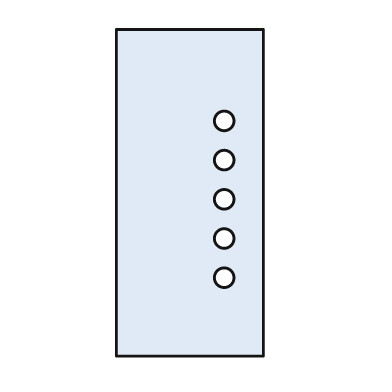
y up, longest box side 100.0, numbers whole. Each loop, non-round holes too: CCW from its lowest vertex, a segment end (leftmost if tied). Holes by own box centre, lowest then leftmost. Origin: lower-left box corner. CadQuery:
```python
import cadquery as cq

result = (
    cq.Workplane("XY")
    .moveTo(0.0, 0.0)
    .lineTo(45.0, 0.0)
    .lineTo(45.0, 100.0)
    .lineTo(0.0, 100.0)
    .close()
    .moveTo(33.0, 24.0)
    .circle(3.0)
    .moveTo(33.0, 36.0)
    .circle(3.0)
    .moveTo(33.0, 48.0)
    .circle(3.0)
    .moveTo(33.0, 60.0)
    .circle(3.0)
    .moveTo(33.0, 72.0)
    .circle(3.0)
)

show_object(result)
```